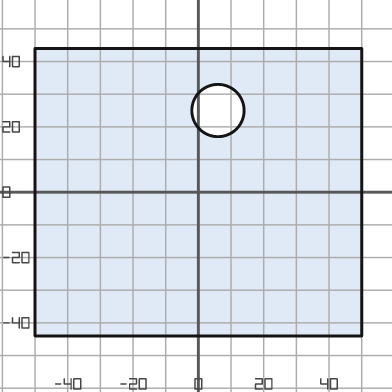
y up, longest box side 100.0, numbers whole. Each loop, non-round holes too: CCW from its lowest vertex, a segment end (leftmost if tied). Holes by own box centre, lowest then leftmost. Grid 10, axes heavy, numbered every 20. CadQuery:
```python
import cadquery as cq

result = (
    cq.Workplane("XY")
    .moveTo(-50.0, -44.0)
    .lineTo(50.0, -44.0)
    .lineTo(50.0, 44.0)
    .lineTo(-50.0, 44.0)
    .close()
    .moveTo(6.0, 25.0)
    .circle(8.0)
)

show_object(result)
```